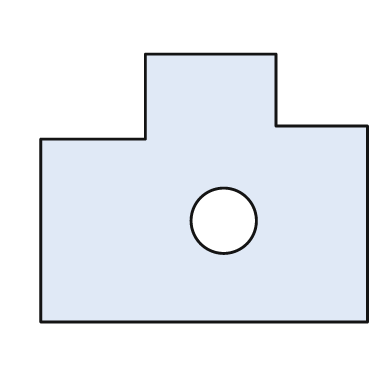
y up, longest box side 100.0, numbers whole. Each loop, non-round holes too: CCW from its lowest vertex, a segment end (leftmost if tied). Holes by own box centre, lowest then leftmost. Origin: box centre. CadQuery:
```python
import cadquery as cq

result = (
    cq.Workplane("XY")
    .moveTo(-50.0, -41.0)
    .lineTo(50.0, -41.0)
    .lineTo(50.0, 19.0)
    .lineTo(22.0, 19.0)
    .lineTo(22.0, 41.0)
    .lineTo(-18.0, 41.0)
    .lineTo(-18.0, 15.0)
    .lineTo(-50.0, 15.0)
    .close()
    .moveTo(6.0, -10.0)
    .circle(10.0)
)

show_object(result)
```